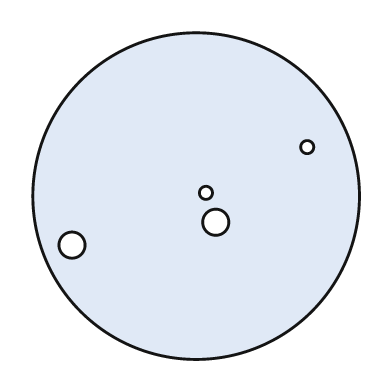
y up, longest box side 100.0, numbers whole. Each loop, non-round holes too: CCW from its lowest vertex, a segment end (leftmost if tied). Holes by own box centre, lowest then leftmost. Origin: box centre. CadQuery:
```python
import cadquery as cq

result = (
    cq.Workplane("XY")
    .moveTo(0.0, 0.0)
    .circle(50.0)
    .moveTo(-38.0, -15.0)
    .circle(4.0)
    .moveTo(6.0, -8.0)
    .circle(4.0)
    .moveTo(3.0, 1.0)
    .circle(2.0)
    .moveTo(34.0, 15.0)
    .circle(2.0)
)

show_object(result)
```